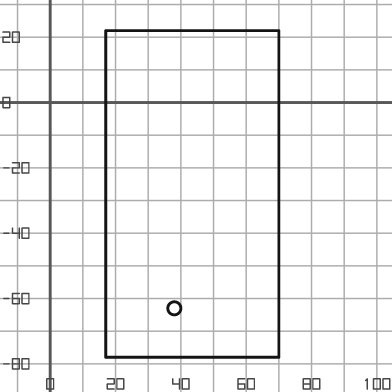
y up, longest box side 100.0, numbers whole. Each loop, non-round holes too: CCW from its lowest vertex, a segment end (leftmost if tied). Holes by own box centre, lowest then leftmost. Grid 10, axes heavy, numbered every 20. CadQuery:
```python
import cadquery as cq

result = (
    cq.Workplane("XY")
    .moveTo(17.0, -78.0)
    .lineTo(70.0, -78.0)
    .lineTo(70.0, 22.0)
    .lineTo(17.0, 22.0)
    .close()
    .moveTo(38.0, -63.0)
    .circle(2.0)
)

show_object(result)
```